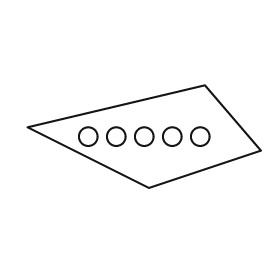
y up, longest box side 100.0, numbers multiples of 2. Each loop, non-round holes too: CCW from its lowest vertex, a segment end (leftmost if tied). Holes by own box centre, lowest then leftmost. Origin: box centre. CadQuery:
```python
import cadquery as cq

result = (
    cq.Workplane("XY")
    .moveTo(2.0, -22.0)
    .lineTo(50.0, -6.0)
    .lineTo(26.0, 22.0)
    .lineTo(-50.0, 4.0)
    .close()
    .moveTo(-24.0, 0.0)
    .circle(4.0)
    .moveTo(-12.0, 0.0)
    .circle(4.0)
    .moveTo(0.0, 0.0)
    .circle(4.0)
    .moveTo(12.0, 0.0)
    .circle(4.0)
    .moveTo(24.0, 0.0)
    .circle(4.0)
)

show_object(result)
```